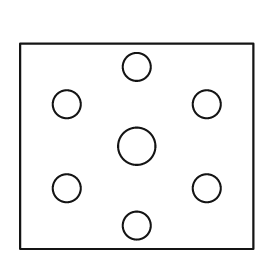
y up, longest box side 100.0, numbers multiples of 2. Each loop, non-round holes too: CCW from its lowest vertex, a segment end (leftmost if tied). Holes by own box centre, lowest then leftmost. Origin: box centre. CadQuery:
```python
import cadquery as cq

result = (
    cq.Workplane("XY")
    .moveTo(-50.0, -44.0)
    .lineTo(50.0, -44.0)
    .lineTo(50.0, 44.0)
    .lineTo(-50.0, 44.0)
    .close()
    .moveTo(0.0, -34.0)
    .circle(6.0)
    .moveTo(-30.0, -18.0)
    .circle(6.0)
    .moveTo(30.0, -18.0)
    .circle(6.0)
    .moveTo(0.0, 0.0)
    .circle(8.0)
    .moveTo(-30.0, 18.0)
    .circle(6.0)
    .moveTo(30.0, 18.0)
    .circle(6.0)
    .moveTo(0.0, 34.0)
    .circle(6.0)
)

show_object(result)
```